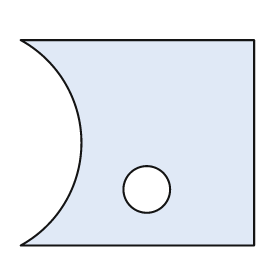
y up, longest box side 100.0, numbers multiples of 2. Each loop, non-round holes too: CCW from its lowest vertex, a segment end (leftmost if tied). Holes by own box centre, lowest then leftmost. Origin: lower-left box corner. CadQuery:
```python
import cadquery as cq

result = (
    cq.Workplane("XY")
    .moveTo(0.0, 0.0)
    .lineTo(100.0, 0.0)
    .lineTo(100.0, 88.0)
    .lineTo(0.0, 88.0)
    .threePointArc((26.0, 44.0), (0.0, 0.0))
    .close()
    .moveTo(54.0, 24.0)
    .circle(10.0)
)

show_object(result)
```